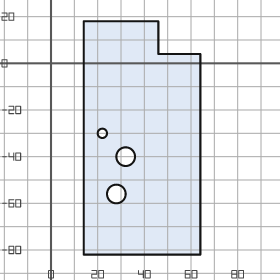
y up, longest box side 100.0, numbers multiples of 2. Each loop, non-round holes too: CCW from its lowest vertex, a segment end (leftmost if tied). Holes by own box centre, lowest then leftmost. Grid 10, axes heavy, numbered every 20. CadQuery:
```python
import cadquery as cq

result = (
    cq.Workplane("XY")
    .moveTo(14.0, -82.0)
    .lineTo(64.0, -82.0)
    .lineTo(64.0, 4.0)
    .lineTo(46.0, 4.0)
    .lineTo(46.0, 18.0)
    .lineTo(14.0, 18.0)
    .close()
    .moveTo(28.0, -56.0)
    .circle(4.0)
    .moveTo(32.0, -40.0)
    .circle(4.0)
    .moveTo(22.0, -30.0)
    .circle(2.0)
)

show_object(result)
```